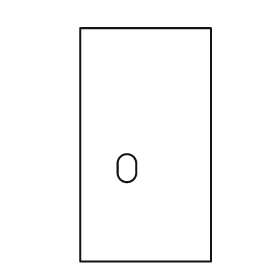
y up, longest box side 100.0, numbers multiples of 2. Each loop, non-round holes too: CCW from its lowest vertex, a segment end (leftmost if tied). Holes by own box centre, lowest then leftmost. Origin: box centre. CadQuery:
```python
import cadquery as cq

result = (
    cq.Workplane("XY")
    .moveTo(-28.0, -50.0)
    .lineTo(28.0, -50.0)
    .lineTo(28.0, 50.0)
    .lineTo(-28.0, 50.0)
    .close()
    .moveTo(-12.0, -12.0)
    .threePointArc((-8.0, -16.0), (-4.0, -12.0))
    .lineTo(-4.0, -8.0)
    .threePointArc((-8.0, -4.0), (-12.0, -8.0))
    .close()
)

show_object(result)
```